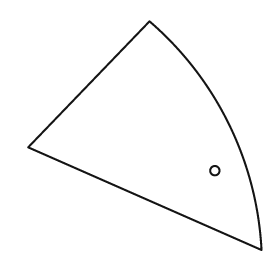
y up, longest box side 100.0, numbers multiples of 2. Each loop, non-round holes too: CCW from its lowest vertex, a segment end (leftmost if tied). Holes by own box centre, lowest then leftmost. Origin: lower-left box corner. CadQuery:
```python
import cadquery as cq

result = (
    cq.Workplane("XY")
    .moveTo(100.0, 0.0)
    .threePointArc((86.0, 54.0), (52.0, 98.0))
    .lineTo(0.0, 44.0)
    .close()
    .moveTo(80.0, 34.0)
    .circle(2.0)
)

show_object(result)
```